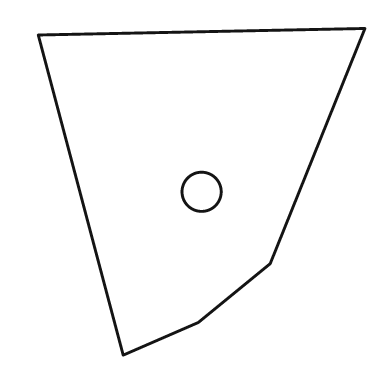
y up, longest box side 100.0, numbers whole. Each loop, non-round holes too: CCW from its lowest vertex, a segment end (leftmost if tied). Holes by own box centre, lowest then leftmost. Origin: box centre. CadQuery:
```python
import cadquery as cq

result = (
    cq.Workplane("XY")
    .moveTo(-24.0, -50.0)
    .lineTo(-1.0, -40.0)
    .lineTo(21.0, -22.0)
    .lineTo(50.0, 50.0)
    .lineTo(-50.0, 48.0)
    .close()
    .moveTo(0.0, 0.0)
    .circle(6.0)
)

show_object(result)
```